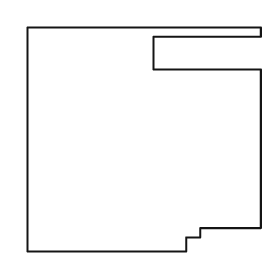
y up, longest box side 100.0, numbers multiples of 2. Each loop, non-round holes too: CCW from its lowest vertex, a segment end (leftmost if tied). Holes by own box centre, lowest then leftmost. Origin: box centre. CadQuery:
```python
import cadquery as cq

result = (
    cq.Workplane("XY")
    .moveTo(-50.0, -48.0)
    .lineTo(18.0, -48.0)
    .lineTo(18.0, -42.0)
    .lineTo(24.0, -42.0)
    .lineTo(24.0, -38.0)
    .lineTo(50.0, -38.0)
    .lineTo(50.0, 30.0)
    .lineTo(4.0, 30.0)
    .lineTo(4.0, 44.0)
    .lineTo(50.0, 44.0)
    .lineTo(50.0, 48.0)
    .lineTo(-50.0, 48.0)
    .close()
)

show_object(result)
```